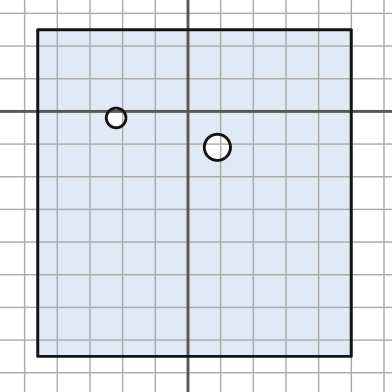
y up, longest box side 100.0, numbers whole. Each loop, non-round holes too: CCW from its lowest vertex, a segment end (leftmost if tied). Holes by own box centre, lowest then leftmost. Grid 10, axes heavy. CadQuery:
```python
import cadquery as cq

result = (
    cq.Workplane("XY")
    .moveTo(-46.0, -75.0)
    .lineTo(50.0, -75.0)
    .lineTo(50.0, 25.0)
    .lineTo(-46.0, 25.0)
    .close()
    .moveTo(9.0, -11.0)
    .circle(4.0)
    .moveTo(-22.0, -2.0)
    .circle(3.0)
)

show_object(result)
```